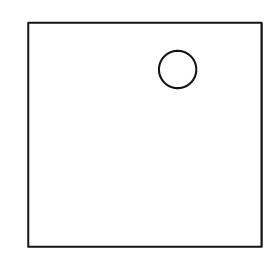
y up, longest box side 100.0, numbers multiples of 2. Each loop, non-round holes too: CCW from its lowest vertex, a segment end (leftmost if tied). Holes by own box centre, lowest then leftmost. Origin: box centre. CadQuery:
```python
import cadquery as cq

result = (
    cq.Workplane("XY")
    .moveTo(-50.0, -48.0)
    .lineTo(50.0, -48.0)
    .lineTo(50.0, 48.0)
    .lineTo(-50.0, 48.0)
    .close()
    .moveTo(14.0, 28.0)
    .circle(8.0)
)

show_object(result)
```